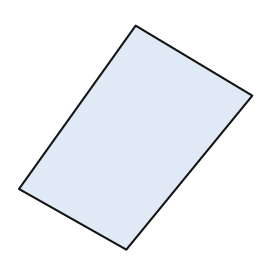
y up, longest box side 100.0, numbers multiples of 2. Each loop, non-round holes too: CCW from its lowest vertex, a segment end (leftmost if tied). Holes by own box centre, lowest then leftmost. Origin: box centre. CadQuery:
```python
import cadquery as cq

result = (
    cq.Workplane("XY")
    .moveTo(-4.0, -48.0)
    .lineTo(50.0, 18.0)
    .lineTo(0.0, 48.0)
    .lineTo(-50.0, -22.0)
    .close()
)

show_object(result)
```